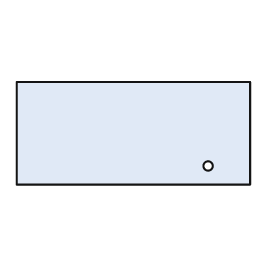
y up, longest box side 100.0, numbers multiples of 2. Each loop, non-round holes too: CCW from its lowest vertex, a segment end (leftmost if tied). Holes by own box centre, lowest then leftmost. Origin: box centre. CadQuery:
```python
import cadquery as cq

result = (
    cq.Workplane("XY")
    .moveTo(-50.0, -22.0)
    .lineTo(50.0, -22.0)
    .lineTo(50.0, 22.0)
    .lineTo(-50.0, 22.0)
    .close()
    .moveTo(32.0, -14.0)
    .circle(2.0)
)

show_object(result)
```